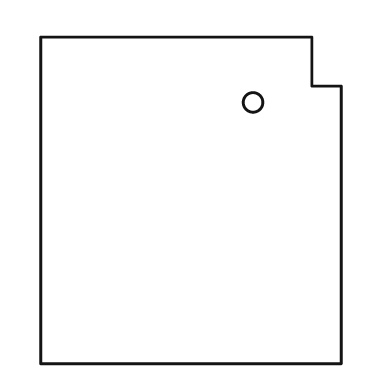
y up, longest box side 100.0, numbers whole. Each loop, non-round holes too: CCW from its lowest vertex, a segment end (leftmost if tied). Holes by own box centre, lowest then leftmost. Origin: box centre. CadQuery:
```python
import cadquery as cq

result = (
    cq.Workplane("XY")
    .moveTo(-46.0, -50.0)
    .lineTo(46.0, -50.0)
    .lineTo(46.0, 35.0)
    .lineTo(37.0, 35.0)
    .lineTo(37.0, 50.0)
    .lineTo(-46.0, 50.0)
    .close()
    .moveTo(19.0, 30.0)
    .circle(3.0)
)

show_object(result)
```